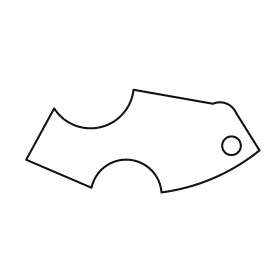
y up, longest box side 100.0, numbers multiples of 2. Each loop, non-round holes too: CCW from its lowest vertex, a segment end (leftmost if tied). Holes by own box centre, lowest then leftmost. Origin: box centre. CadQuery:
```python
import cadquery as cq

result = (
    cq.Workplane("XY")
    .moveTo(8.0, -22.0)
    .threePointArc((30.0, -16.0), (50.0, -4.0))
    .lineTo(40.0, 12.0)
    .threePointArc((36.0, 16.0), (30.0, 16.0))
    .lineTo(-4.0, 22.0)
    .threePointArc((-18.0, 6.0), (-38.0, 14.0))
    .lineTo(-50.0, -8.0)
    .lineTo(-22.0, -20.0)
    .threePointArc((-6.0, -8.0), (8.0, -22.0))
    .close()
    .moveTo(38.0, -2.0)
    .circle(4.0)
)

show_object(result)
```